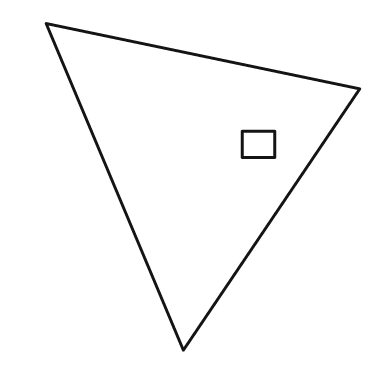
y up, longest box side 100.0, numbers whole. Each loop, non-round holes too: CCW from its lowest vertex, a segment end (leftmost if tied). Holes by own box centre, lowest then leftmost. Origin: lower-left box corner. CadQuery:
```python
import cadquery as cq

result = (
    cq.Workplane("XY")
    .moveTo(42.0, 0.0)
    .lineTo(96.0, 80.0)
    .lineTo(0.0, 100.0)
    .close()
    .moveTo(60.0, 59.0)
    .lineTo(70.0, 59.0)
    .lineTo(70.0, 67.0)
    .lineTo(60.0, 67.0)
    .close()
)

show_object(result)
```